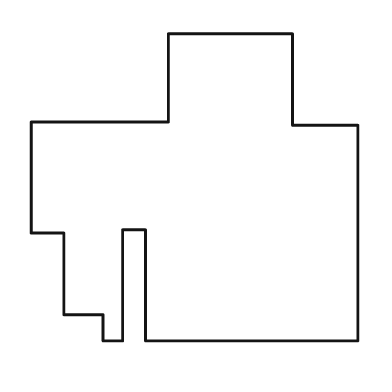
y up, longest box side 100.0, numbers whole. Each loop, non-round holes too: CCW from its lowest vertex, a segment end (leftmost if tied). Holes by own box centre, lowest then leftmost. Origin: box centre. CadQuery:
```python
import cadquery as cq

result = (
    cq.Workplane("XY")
    .moveTo(-28.0, -47.0)
    .lineTo(-22.0, -47.0)
    .lineTo(-22.0, -13.0)
    .lineTo(-15.0, -13.0)
    .lineTo(-15.0, -47.0)
    .lineTo(50.0, -47.0)
    .lineTo(50.0, 19.0)
    .lineTo(30.0, 19.0)
    .lineTo(30.0, 47.0)
    .lineTo(-8.0, 47.0)
    .lineTo(-8.0, 20.0)
    .lineTo(-50.0, 20.0)
    .lineTo(-50.0, -14.0)
    .lineTo(-40.0, -14.0)
    .lineTo(-40.0, -39.0)
    .lineTo(-28.0, -39.0)
    .close()
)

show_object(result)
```